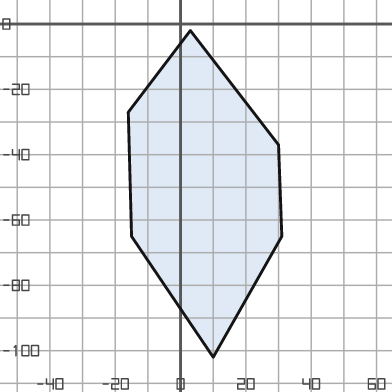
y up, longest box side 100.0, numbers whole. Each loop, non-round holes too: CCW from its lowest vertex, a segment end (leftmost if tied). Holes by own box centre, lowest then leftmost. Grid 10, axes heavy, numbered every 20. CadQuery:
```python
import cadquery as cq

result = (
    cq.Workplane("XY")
    .moveTo(10.0, -102.0)
    .lineTo(31.0, -65.0)
    .lineTo(30.0, -37.0)
    .lineTo(3.0, -2.0)
    .lineTo(-16.0, -27.0)
    .lineTo(-15.0, -65.0)
    .close()
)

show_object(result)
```